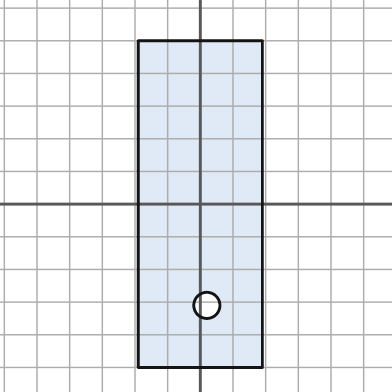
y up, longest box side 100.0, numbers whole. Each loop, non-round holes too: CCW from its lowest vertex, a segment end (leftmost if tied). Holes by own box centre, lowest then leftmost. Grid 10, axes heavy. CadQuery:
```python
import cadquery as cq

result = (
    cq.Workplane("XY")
    .moveTo(-19.0, -50.0)
    .lineTo(19.0, -50.0)
    .lineTo(19.0, 50.0)
    .lineTo(-19.0, 50.0)
    .close()
    .moveTo(2.0, -31.0)
    .circle(4.0)
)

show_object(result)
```